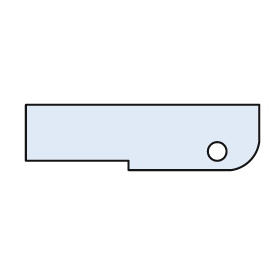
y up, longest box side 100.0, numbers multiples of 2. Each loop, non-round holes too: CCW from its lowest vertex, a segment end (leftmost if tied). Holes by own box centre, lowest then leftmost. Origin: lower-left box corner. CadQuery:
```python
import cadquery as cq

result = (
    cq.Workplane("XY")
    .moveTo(44.0, 0.0)
    .lineTo(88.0, 0.0)
    .threePointArc((96.0, 4.0), (100.0, 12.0))
    .lineTo(100.0, 28.0)
    .lineTo(0.0, 28.0)
    .lineTo(0.0, 4.0)
    .lineTo(44.0, 4.0)
    .close()
    .moveTo(82.0, 8.0)
    .circle(4.0)
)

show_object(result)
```